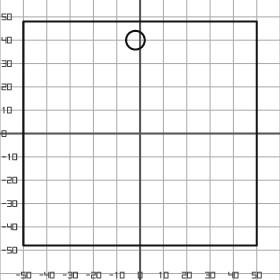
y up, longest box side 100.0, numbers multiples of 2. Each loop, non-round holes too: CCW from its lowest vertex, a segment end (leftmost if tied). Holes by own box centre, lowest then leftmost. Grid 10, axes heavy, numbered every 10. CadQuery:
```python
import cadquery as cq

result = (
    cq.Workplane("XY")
    .moveTo(-50.0, -48.0)
    .lineTo(50.0, -48.0)
    .lineTo(50.0, 48.0)
    .lineTo(-50.0, 48.0)
    .close()
    .moveTo(-2.0, 40.0)
    .circle(4.0)
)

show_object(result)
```